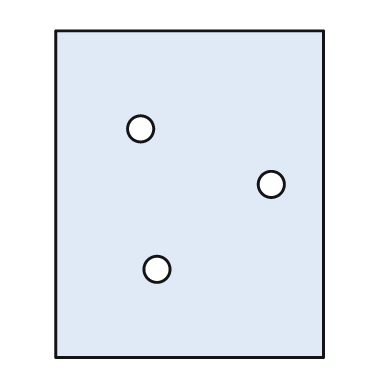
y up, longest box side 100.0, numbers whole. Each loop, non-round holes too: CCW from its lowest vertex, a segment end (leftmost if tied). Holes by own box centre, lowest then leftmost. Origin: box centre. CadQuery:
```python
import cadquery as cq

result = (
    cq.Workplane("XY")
    .moveTo(-41.0, -50.0)
    .lineTo(41.0, -50.0)
    .lineTo(41.0, 50.0)
    .lineTo(-41.0, 50.0)
    .close()
    .moveTo(-10.0, -23.0)
    .circle(4.0)
    .moveTo(25.0, 3.0)
    .circle(4.0)
    .moveTo(-15.0, 20.0)
    .circle(4.0)
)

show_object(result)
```